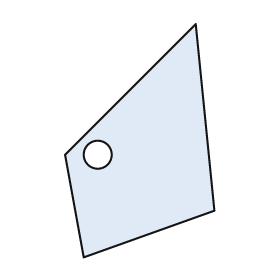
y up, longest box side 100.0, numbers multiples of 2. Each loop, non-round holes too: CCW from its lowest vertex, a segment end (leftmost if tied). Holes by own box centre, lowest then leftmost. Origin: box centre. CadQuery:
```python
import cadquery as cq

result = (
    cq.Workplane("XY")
    .moveTo(-24.0, -50.0)
    .lineTo(32.0, -30.0)
    .lineTo(24.0, 50.0)
    .lineTo(-32.0, -6.0)
    .close()
    .moveTo(-18.0, -6.0)
    .circle(6.0)
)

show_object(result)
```